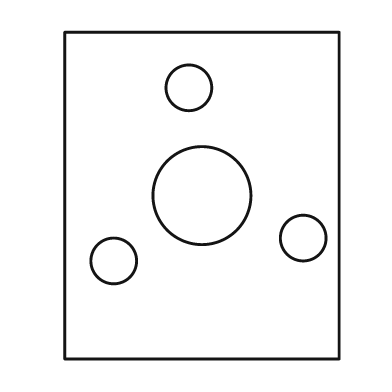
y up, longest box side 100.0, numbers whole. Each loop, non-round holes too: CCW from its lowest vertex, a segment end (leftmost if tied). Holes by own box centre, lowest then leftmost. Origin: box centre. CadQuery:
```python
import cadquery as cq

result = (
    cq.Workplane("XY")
    .moveTo(-42.0, -50.0)
    .lineTo(42.0, -50.0)
    .lineTo(42.0, 50.0)
    .lineTo(-42.0, 50.0)
    .close()
    .moveTo(-27.0, -20.0)
    .circle(7.0)
    .moveTo(31.0, -13.0)
    .circle(7.0)
    .moveTo(0.0, 0.0)
    .circle(15.0)
    .moveTo(-4.0, 33.0)
    .circle(7.0)
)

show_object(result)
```